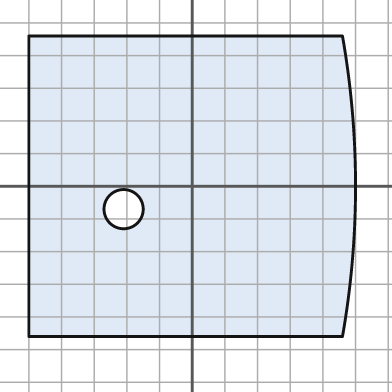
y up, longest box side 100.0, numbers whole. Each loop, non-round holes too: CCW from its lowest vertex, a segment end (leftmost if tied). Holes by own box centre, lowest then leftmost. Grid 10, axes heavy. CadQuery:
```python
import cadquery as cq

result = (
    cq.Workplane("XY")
    .moveTo(-50.0, -46.0)
    .lineTo(46.0, -46.0)
    .threePointArc((50.0, 0.0), (46.0, 46.0))
    .lineTo(-50.0, 46.0)
    .close()
    .moveTo(-21.0, -7.0)
    .circle(6.0)
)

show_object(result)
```